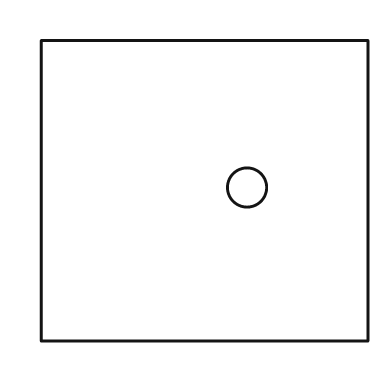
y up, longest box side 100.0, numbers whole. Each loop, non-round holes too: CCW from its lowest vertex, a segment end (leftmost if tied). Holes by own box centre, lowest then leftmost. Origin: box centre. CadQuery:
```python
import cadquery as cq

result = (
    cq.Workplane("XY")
    .moveTo(-50.0, -46.0)
    .lineTo(50.0, -46.0)
    .lineTo(50.0, 46.0)
    .lineTo(-50.0, 46.0)
    .close()
    .moveTo(13.0, 1.0)
    .circle(6.0)
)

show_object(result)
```